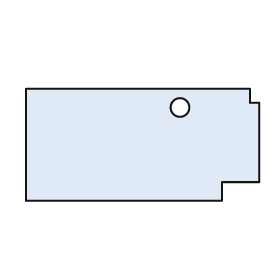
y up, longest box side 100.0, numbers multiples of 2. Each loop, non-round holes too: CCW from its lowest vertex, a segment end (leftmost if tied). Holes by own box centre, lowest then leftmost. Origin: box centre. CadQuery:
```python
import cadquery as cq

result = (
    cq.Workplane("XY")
    .moveTo(-50.0, -24.0)
    .lineTo(34.0, -24.0)
    .lineTo(34.0, -16.0)
    .lineTo(50.0, -16.0)
    .lineTo(50.0, 18.0)
    .lineTo(46.0, 18.0)
    .lineTo(46.0, 24.0)
    .lineTo(-50.0, 24.0)
    .close()
    .moveTo(16.0, 16.0)
    .circle(4.0)
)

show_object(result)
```